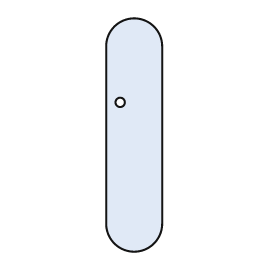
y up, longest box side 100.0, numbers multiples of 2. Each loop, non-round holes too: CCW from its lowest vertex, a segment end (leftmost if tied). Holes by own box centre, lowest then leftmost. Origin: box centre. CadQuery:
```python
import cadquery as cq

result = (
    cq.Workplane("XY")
    .moveTo(-12.0, -38.0)
    .threePointArc((0.0, -50.0), (12.0, -38.0))
    .lineTo(12.0, 38.0)
    .threePointArc((0.0, 50.0), (-12.0, 38.0))
    .close()
    .moveTo(-6.0, 14.0)
    .circle(2.0)
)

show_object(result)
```